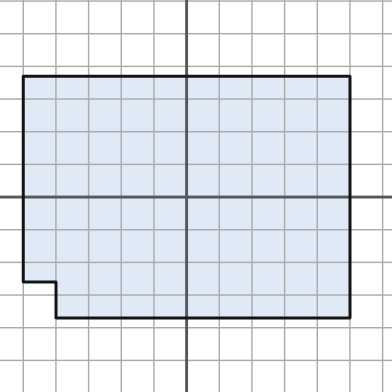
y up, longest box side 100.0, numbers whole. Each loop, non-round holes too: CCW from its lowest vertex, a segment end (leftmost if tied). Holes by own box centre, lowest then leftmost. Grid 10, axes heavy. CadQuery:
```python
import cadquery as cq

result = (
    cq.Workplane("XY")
    .moveTo(-40.0, -37.0)
    .lineTo(50.0, -37.0)
    .lineTo(50.0, 37.0)
    .lineTo(-50.0, 37.0)
    .lineTo(-50.0, -26.0)
    .lineTo(-40.0, -26.0)
    .close()
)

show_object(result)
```